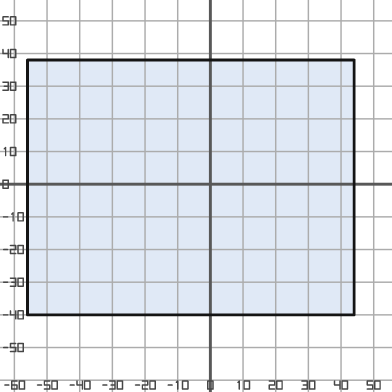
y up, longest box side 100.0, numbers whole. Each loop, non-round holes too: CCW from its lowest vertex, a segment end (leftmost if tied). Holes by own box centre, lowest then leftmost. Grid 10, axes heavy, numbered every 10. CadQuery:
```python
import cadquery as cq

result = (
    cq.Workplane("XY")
    .moveTo(-56.0, -40.0)
    .lineTo(44.0, -40.0)
    .lineTo(44.0, 38.0)
    .lineTo(-56.0, 38.0)
    .close()
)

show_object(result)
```